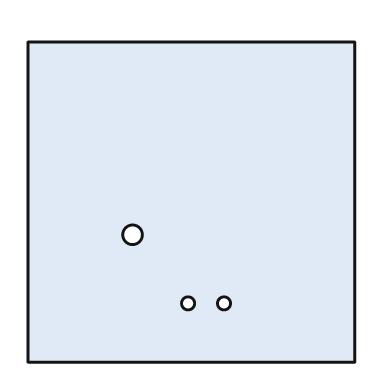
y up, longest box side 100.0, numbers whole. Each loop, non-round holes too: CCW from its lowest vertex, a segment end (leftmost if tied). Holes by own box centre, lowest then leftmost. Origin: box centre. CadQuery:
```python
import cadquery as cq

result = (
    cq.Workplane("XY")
    .moveTo(-50.0, -49.0)
    .lineTo(50.0, -49.0)
    .lineTo(50.0, 49.0)
    .lineTo(-50.0, 49.0)
    .close()
    .moveTo(-1.0, -31.0)
    .circle(2.0)
    .moveTo(10.0, -31.0)
    .circle(2.0)
    .moveTo(-18.0, -10.0)
    .circle(3.0)
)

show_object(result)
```